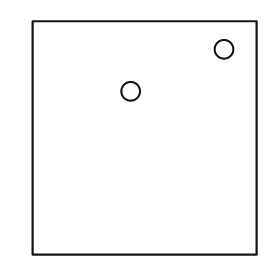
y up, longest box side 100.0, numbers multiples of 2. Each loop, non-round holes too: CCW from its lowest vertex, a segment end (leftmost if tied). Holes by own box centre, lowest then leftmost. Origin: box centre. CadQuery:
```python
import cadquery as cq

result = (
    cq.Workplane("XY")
    .moveTo(-48.0, -50.0)
    .lineTo(48.0, -50.0)
    .lineTo(48.0, 50.0)
    .lineTo(-48.0, 50.0)
    .close()
    .moveTo(-6.0, 20.0)
    .circle(4.0)
    .moveTo(34.0, 38.0)
    .circle(4.0)
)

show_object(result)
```